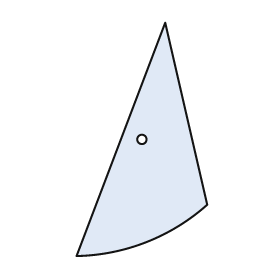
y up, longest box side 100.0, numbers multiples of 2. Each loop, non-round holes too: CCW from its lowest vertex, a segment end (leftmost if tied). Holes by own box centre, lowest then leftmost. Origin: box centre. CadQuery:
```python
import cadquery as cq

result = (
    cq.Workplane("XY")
    .moveTo(-28.0, -50.0)
    .threePointArc((2.0, -44.0), (28.0, -28.0))
    .lineTo(10.0, 50.0)
    .close()
    .moveTo(0.0, 0.0)
    .circle(2.0)
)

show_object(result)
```